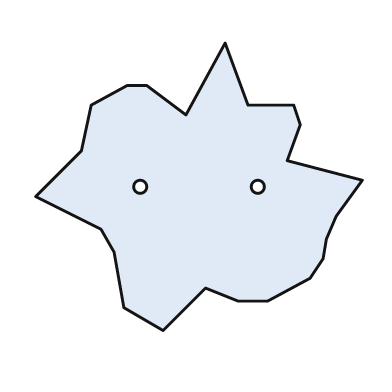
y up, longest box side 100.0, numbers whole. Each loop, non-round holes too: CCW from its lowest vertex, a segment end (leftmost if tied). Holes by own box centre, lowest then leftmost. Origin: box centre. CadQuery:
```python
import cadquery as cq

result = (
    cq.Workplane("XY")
    .moveTo(-11.0, -44.0)
    .lineTo(2.0, -31.0)
    .lineTo(12.0, -35.0)
    .lineTo(21.0, -35.0)
    .lineTo(34.0, -28.0)
    .lineTo(38.0, -22.0)
    .lineTo(39.0, -16.0)
    .lineTo(42.0, -9.0)
    .lineTo(50.0, 2.0)
    .lineTo(27.0, 8.0)
    .lineTo(31.0, 19.0)
    .lineTo(29.0, 25.0)
    .lineTo(15.0, 25.0)
    .lineTo(8.0, 44.0)
    .lineTo(-4.0, 22.0)
    .lineTo(-16.0, 31.0)
    .lineTo(-22.0, 31.0)
    .lineTo(-33.0, 25.0)
    .lineTo(-36.0, 11.0)
    .lineTo(-50.0, -3.0)
    .lineTo(-30.0, -13.0)
    .lineTo(-26.0, -20.0)
    .lineTo(-23.0, -37.0)
    .close()
    .moveTo(-18.0, 0.0)
    .circle(2.0)
    .moveTo(18.0, 0.0)
    .circle(2.0)
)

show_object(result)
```